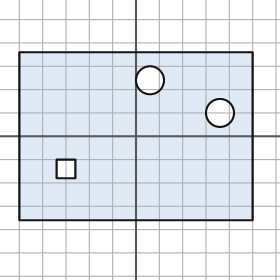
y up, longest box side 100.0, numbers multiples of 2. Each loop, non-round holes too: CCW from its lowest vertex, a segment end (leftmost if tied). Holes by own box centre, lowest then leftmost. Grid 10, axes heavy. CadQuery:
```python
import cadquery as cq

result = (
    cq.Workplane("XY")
    .moveTo(-50.0, -36.0)
    .lineTo(50.0, -36.0)
    .lineTo(50.0, 36.0)
    .lineTo(-50.0, 36.0)
    .close()
    .moveTo(-34.0, -18.0)
    .lineTo(-26.0, -18.0)
    .lineTo(-26.0, -10.0)
    .lineTo(-34.0, -10.0)
    .close()
    .moveTo(36.0, 10.0)
    .circle(6.0)
    .moveTo(6.0, 24.0)
    .circle(6.0)
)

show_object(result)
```